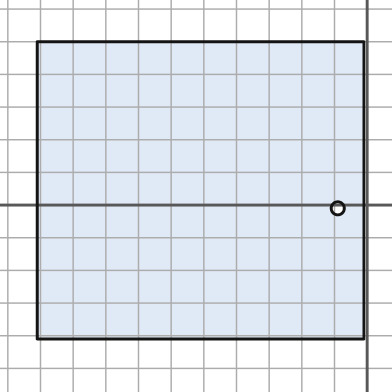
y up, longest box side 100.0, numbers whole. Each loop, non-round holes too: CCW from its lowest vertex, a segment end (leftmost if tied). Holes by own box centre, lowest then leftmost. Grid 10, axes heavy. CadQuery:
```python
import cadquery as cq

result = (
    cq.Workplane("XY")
    .moveTo(-101.0, -41.0)
    .lineTo(-1.0, -41.0)
    .lineTo(-1.0, 50.0)
    .lineTo(-101.0, 50.0)
    .close()
    .moveTo(-9.0, -1.0)
    .circle(2.0)
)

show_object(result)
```